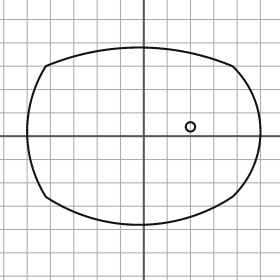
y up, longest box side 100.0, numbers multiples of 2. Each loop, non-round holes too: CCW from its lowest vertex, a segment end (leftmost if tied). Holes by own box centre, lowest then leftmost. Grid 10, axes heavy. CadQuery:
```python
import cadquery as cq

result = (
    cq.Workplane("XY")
    .moveTo(-42.0, -26.0)
    .threePointArc((-2.0, -38.0), (38.0, -26.0))
    .threePointArc((50.0, 2.0), (38.0, 30.0))
    .threePointArc((-2.0, 38.0), (-42.0, 30.0))
    .threePointArc((-50.0, 2.0), (-42.0, -26.0))
    .close()
    .moveTo(20.0, 4.0)
    .circle(2.0)
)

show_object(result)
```